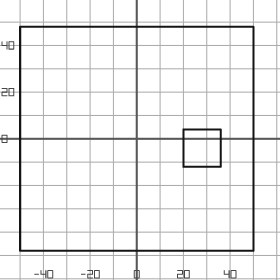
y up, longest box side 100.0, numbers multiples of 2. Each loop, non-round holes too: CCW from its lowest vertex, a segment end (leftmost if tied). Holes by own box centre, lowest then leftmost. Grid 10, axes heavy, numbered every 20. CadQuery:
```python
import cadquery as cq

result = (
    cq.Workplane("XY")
    .moveTo(-50.0, -48.0)
    .lineTo(50.0, -48.0)
    .lineTo(50.0, 48.0)
    .lineTo(-50.0, 48.0)
    .close()
    .moveTo(20.0, -12.0)
    .lineTo(36.0, -12.0)
    .lineTo(36.0, 4.0)
    .lineTo(20.0, 4.0)
    .close()
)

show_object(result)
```